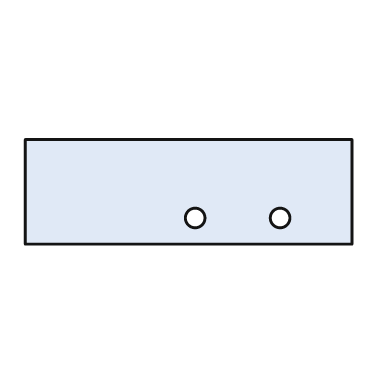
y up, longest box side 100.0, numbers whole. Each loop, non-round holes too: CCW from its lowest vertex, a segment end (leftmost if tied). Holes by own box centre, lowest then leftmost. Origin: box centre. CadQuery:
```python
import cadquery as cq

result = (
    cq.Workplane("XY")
    .moveTo(-50.0, -16.0)
    .lineTo(50.0, -16.0)
    .lineTo(50.0, 16.0)
    .lineTo(-50.0, 16.0)
    .close()
    .moveTo(2.0, -8.0)
    .circle(3.0)
    .moveTo(28.0, -8.0)
    .circle(3.0)
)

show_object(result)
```